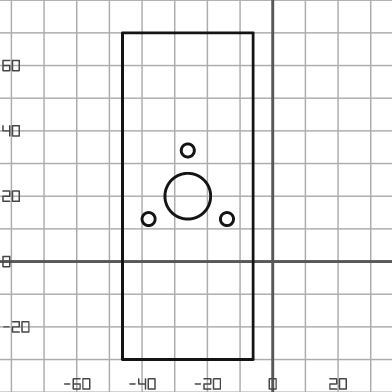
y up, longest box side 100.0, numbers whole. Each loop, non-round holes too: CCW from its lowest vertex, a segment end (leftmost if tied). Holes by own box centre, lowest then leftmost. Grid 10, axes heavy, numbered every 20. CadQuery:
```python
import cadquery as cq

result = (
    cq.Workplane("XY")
    .moveTo(-46.0, -30.0)
    .lineTo(-6.0, -30.0)
    .lineTo(-6.0, 70.0)
    .lineTo(-46.0, 70.0)
    .close()
    .moveTo(-38.0, 13.0)
    .circle(2.0)
    .moveTo(-14.0, 13.0)
    .circle(2.0)
    .moveTo(-26.0, 20.0)
    .circle(7.0)
    .moveTo(-26.0, 34.0)
    .circle(2.0)
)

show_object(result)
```